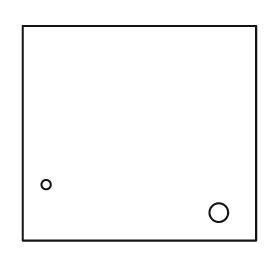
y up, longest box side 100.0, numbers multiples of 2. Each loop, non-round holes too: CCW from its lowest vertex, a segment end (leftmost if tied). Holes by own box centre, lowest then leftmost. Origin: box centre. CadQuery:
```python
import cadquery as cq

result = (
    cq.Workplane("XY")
    .moveTo(-50.0, -46.0)
    .lineTo(50.0, -46.0)
    .lineTo(50.0, 46.0)
    .lineTo(-50.0, 46.0)
    .close()
    .moveTo(34.0, -34.0)
    .circle(4.0)
    .moveTo(-40.0, -22.0)
    .circle(2.0)
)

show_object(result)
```